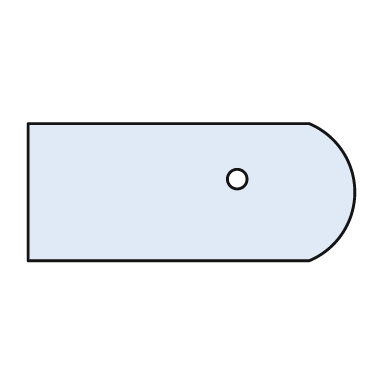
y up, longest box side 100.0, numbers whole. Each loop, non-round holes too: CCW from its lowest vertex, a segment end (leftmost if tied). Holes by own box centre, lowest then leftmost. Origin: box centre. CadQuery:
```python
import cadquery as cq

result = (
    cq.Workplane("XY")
    .moveTo(-50.0, -21.0)
    .lineTo(36.0, -21.0)
    .threePointArc((50.0, 0.0), (36.0, 21.0))
    .lineTo(-50.0, 21.0)
    .close()
    .moveTo(14.0, 4.0)
    .circle(3.0)
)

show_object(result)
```